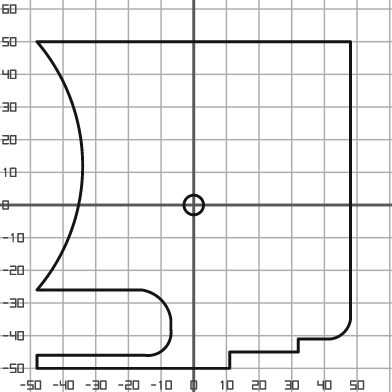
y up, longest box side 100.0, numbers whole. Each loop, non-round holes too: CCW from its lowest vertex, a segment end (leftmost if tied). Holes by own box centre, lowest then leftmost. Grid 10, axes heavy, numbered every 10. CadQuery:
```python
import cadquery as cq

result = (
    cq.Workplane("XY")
    .moveTo(-48.0, -50.0)
    .lineTo(11.0, -50.0)
    .lineTo(11.0, -45.0)
    .lineTo(32.0, -45.0)
    .lineTo(32.0, -41.0)
    .lineTo(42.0, -41.0)
    .threePointArc((46.0, -39.0), (48.0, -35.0))
    .lineTo(48.0, 50.0)
    .lineTo(-48.0, 50.0)
    .threePointArc((-34.0, 12.0), (-48.0, -26.0))
    .lineTo(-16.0, -26.0)
    .threePointArc((-10.0, -29.0), (-7.0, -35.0))
    .lineTo(-7.0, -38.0)
    .threePointArc((-9.0, -44.0), (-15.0, -46.0))
    .lineTo(-48.0, -46.0)
    .close()
    .moveTo(0.0, 0.0)
    .circle(3.0)
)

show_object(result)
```